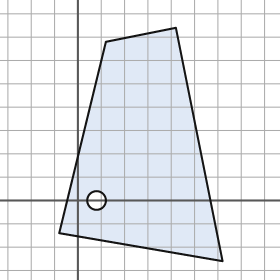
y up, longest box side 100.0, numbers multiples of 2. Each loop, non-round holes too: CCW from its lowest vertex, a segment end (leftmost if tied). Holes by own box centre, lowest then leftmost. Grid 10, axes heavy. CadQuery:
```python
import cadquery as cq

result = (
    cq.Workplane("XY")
    .moveTo(62.0, -26.0)
    .lineTo(42.0, 74.0)
    .lineTo(12.0, 68.0)
    .lineTo(-8.0, -14.0)
    .close()
    .moveTo(8.0, 0.0)
    .circle(4.0)
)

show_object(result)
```